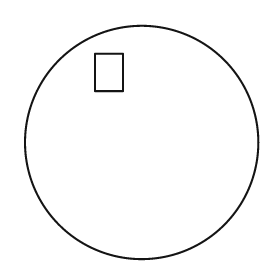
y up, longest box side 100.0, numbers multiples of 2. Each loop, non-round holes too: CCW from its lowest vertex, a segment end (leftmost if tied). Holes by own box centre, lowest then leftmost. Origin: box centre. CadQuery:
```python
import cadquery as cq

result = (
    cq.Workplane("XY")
    .moveTo(0.0, 0.0)
    .circle(50.0)
    .moveTo(-20.0, 22.0)
    .lineTo(-8.0, 22.0)
    .lineTo(-8.0, 38.0)
    .lineTo(-20.0, 38.0)
    .close()
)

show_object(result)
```